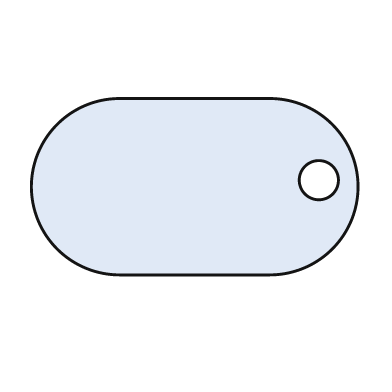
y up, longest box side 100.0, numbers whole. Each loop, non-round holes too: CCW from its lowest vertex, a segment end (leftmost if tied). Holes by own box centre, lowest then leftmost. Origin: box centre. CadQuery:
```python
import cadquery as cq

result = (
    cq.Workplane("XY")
    .moveTo(-23.0, -27.0)
    .lineTo(23.0, -27.0)
    .threePointArc((50.0, 0.0), (23.0, 27.0))
    .lineTo(-23.0, 27.0)
    .threePointArc((-50.0, 0.0), (-23.0, -27.0))
    .close()
    .moveTo(38.0, 2.0)
    .circle(6.0)
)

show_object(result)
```